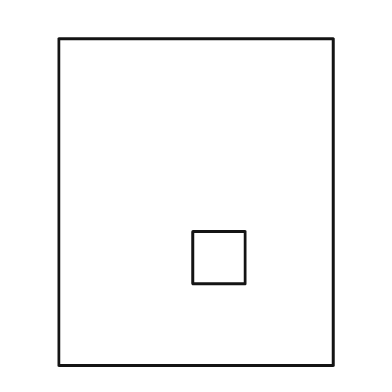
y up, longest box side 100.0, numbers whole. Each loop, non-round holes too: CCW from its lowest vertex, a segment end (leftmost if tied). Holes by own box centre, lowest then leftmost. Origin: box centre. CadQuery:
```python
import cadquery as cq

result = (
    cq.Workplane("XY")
    .moveTo(-42.0, -50.0)
    .lineTo(42.0, -50.0)
    .lineTo(42.0, 50.0)
    .lineTo(-42.0, 50.0)
    .close()
    .moveTo(-1.0, -25.0)
    .lineTo(15.0, -25.0)
    .lineTo(15.0, -9.0)
    .lineTo(-1.0, -9.0)
    .close()
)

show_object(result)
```